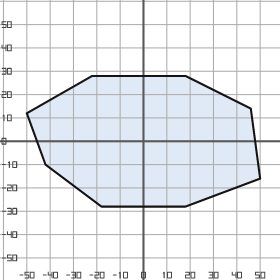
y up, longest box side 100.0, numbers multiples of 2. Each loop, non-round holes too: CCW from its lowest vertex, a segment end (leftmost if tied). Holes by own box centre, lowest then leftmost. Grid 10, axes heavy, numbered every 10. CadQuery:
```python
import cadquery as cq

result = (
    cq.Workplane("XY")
    .moveTo(-18.0, -28.0)
    .lineTo(18.0, -28.0)
    .lineTo(50.0, -16.0)
    .lineTo(46.0, 14.0)
    .lineTo(18.0, 28.0)
    .lineTo(-22.0, 28.0)
    .lineTo(-50.0, 12.0)
    .lineTo(-42.0, -10.0)
    .close()
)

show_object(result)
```